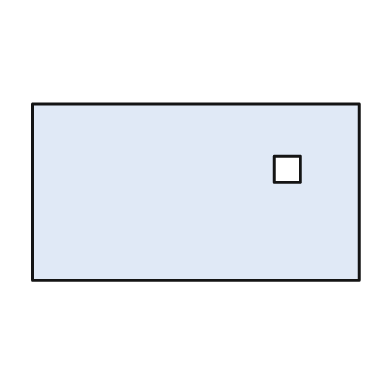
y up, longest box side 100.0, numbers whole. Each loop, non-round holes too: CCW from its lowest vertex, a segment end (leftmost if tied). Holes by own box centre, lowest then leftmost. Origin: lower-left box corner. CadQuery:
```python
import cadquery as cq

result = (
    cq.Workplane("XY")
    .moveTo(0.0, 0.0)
    .lineTo(100.0, 0.0)
    .lineTo(100.0, 54.0)
    .lineTo(0.0, 54.0)
    .close()
    .moveTo(74.0, 30.0)
    .lineTo(82.0, 30.0)
    .lineTo(82.0, 38.0)
    .lineTo(74.0, 38.0)
    .close()
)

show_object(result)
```